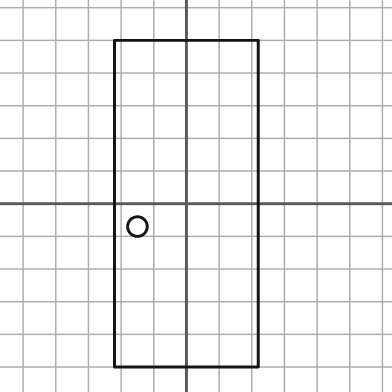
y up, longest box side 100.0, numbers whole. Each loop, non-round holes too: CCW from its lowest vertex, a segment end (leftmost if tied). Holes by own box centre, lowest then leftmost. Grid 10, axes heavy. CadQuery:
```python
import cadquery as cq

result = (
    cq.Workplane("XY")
    .moveTo(-22.0, -50.0)
    .lineTo(22.0, -50.0)
    .lineTo(22.0, 50.0)
    .lineTo(-22.0, 50.0)
    .close()
    .moveTo(-15.0, -7.0)
    .circle(3.0)
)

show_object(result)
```